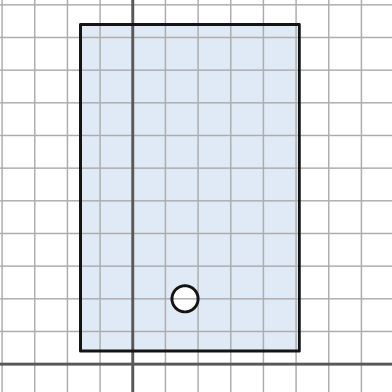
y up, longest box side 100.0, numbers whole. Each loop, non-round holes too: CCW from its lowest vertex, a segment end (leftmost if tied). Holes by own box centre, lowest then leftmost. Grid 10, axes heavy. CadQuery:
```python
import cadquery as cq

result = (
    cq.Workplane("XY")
    .moveTo(-16.0, 4.0)
    .lineTo(51.0, 4.0)
    .lineTo(51.0, 104.0)
    .lineTo(-16.0, 104.0)
    .close()
    .moveTo(16.0, 20.0)
    .circle(4.0)
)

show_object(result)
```